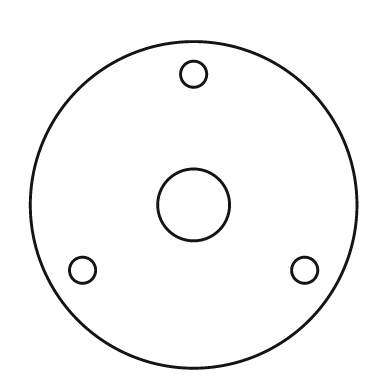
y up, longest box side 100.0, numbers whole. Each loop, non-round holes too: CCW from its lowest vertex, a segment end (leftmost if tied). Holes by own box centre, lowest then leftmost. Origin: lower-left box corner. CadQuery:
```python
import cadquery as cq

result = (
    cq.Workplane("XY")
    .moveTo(50.0, 50.0)
    .circle(50.0)
    .moveTo(16.0, 30.0)
    .circle(4.0)
    .moveTo(84.0, 30.0)
    .circle(4.0)
    .moveTo(50.0, 50.0)
    .circle(11.0)
    .moveTo(50.0, 90.0)
    .circle(4.0)
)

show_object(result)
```